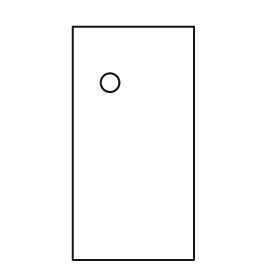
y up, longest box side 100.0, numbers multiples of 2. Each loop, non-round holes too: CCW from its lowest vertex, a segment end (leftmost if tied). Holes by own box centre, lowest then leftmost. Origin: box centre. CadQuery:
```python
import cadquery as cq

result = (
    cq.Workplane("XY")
    .moveTo(-26.0, -50.0)
    .lineTo(26.0, -50.0)
    .lineTo(26.0, 50.0)
    .lineTo(-26.0, 50.0)
    .close()
    .moveTo(-10.0, 26.0)
    .circle(4.0)
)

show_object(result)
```